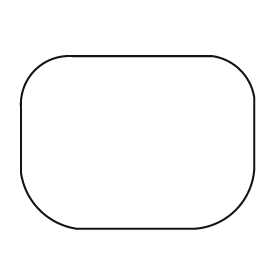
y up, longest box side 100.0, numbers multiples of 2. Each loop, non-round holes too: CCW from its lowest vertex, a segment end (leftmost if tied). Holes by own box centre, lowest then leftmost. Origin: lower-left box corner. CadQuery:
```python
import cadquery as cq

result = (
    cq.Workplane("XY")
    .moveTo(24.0, 0.0)
    .lineTo(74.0, 0.0)
    .threePointArc((92.0, 8.0), (100.0, 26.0))
    .lineTo(100.0, 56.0)
    .threePointArc((94.0, 68.0), (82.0, 74.0))
    .lineTo(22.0, 74.0)
    .threePointArc((6.0, 68.0), (0.0, 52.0))
    .lineTo(0.0, 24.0)
    .threePointArc((8.0, 8.0), (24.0, 0.0))
    .close()
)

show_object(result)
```